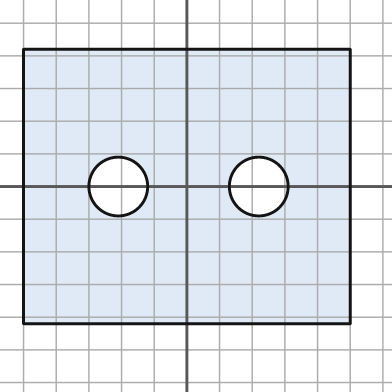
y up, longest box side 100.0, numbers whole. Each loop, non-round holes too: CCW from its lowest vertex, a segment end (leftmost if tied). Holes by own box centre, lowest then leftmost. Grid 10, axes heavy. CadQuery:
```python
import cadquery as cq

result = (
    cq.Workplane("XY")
    .moveTo(-50.0, -42.0)
    .lineTo(50.0, -42.0)
    .lineTo(50.0, 42.0)
    .lineTo(-50.0, 42.0)
    .close()
    .moveTo(-21.0, 0.0)
    .circle(9.0)
    .moveTo(22.0, 0.0)
    .circle(9.0)
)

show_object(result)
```